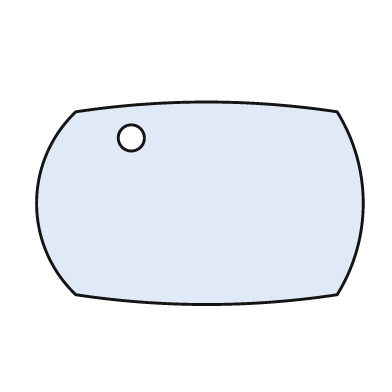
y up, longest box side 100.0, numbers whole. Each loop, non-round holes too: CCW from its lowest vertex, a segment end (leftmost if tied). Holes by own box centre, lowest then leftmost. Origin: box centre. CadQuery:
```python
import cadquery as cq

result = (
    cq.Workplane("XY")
    .moveTo(-38.0, -28.0)
    .threePointArc((2.0, -31.0), (42.0, -28.0))
    .threePointArc((50.0, 0.0), (42.0, 28.0))
    .threePointArc((2.0, 31.0), (-38.0, 28.0))
    .threePointArc((-50.0, 0.0), (-38.0, -28.0))
    .close()
    .moveTo(-21.0, 20.0)
    .circle(4.0)
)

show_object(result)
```